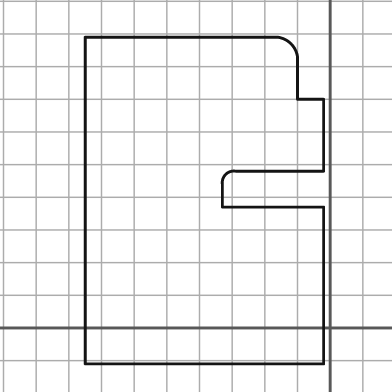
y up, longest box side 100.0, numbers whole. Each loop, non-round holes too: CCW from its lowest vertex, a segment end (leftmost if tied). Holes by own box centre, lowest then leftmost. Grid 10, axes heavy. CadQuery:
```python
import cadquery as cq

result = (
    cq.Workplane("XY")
    .moveTo(-75.0, -11.0)
    .lineTo(-2.0, -11.0)
    .lineTo(-2.0, 37.0)
    .lineTo(-33.0, 37.0)
    .lineTo(-33.0, 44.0)
    .threePointArc((-32.0, 47.0), (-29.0, 48.0))
    .lineTo(-2.0, 48.0)
    .lineTo(-2.0, 70.0)
    .lineTo(-10.0, 70.0)
    .lineTo(-10.0, 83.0)
    .threePointArc((-12.0, 87.0), (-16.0, 89.0))
    .lineTo(-75.0, 89.0)
    .close()
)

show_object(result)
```